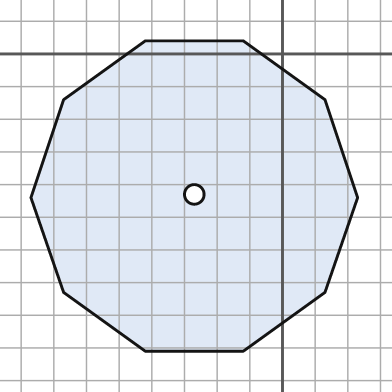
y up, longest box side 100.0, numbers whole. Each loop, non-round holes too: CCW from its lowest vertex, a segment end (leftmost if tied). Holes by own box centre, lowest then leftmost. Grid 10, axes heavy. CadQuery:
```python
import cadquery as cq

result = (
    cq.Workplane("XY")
    .moveTo(-42.0, -91.0)
    .lineTo(-12.0, -91.0)
    .lineTo(13.0, -73.0)
    .lineTo(23.0, -44.0)
    .lineTo(13.0, -14.0)
    .lineTo(-12.0, 4.0)
    .lineTo(-42.0, 4.0)
    .lineTo(-67.0, -14.0)
    .lineTo(-77.0, -44.0)
    .lineTo(-67.0, -73.0)
    .close()
    .moveTo(-27.0, -43.0)
    .circle(3.0)
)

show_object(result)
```